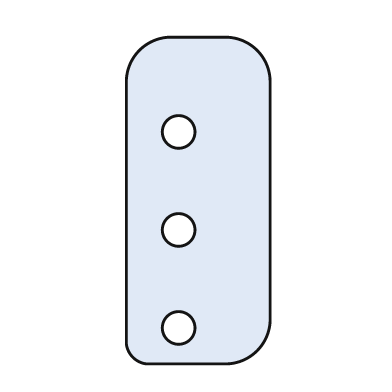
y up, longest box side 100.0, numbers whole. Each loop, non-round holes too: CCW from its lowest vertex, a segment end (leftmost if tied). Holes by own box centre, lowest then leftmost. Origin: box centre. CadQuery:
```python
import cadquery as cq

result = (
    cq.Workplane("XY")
    .moveTo(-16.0, -50.0)
    .lineTo(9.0, -50.0)
    .threePointArc((18.0, -46.0), (22.0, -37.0))
    .lineTo(22.0, 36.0)
    .threePointArc((18.0, 46.0), (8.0, 50.0))
    .lineTo(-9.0, 50.0)
    .threePointArc((-18.0, 46.0), (-22.0, 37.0))
    .lineTo(-22.0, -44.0)
    .threePointArc((-20.0, -48.0), (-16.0, -50.0))
    .close()
    .moveTo(-6.0, -39.0)
    .circle(5.0)
    .moveTo(-6.0, -9.0)
    .circle(5.0)
    .moveTo(-6.0, 21.0)
    .circle(5.0)
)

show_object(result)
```